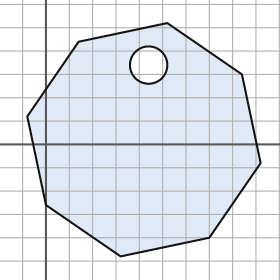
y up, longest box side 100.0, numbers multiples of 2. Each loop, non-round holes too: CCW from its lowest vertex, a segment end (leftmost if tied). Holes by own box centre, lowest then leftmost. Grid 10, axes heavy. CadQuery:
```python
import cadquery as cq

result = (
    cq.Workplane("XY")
    .moveTo(32.0, -48.0)
    .lineTo(70.0, -40.0)
    .lineTo(92.0, -8.0)
    .lineTo(84.0, 30.0)
    .lineTo(52.0, 52.0)
    .lineTo(14.0, 44.0)
    .lineTo(-8.0, 12.0)
    .lineTo(0.0, -26.0)
    .close()
    .moveTo(44.0, 34.0)
    .circle(8.0)
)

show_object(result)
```